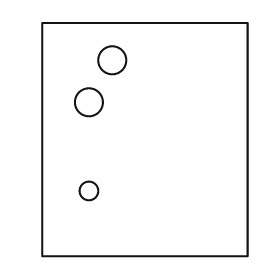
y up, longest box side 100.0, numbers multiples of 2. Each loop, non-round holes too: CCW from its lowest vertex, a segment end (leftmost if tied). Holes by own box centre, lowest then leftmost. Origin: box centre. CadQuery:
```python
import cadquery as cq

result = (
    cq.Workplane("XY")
    .moveTo(-44.0, -50.0)
    .lineTo(44.0, -50.0)
    .lineTo(44.0, 50.0)
    .lineTo(-44.0, 50.0)
    .close()
    .moveTo(-24.0, -22.0)
    .circle(4.0)
    .moveTo(-24.0, 16.0)
    .circle(6.0)
    .moveTo(-14.0, 34.0)
    .circle(6.0)
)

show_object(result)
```